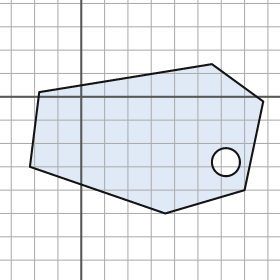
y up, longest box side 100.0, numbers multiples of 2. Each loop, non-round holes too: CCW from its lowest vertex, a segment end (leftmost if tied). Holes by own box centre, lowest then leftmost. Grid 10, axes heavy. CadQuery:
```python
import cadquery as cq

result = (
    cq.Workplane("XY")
    .moveTo(36.0, -50.0)
    .lineTo(70.0, -40.0)
    .lineTo(78.0, -2.0)
    .lineTo(56.0, 14.0)
    .lineTo(-18.0, 2.0)
    .lineTo(-22.0, -30.0)
    .close()
    .moveTo(62.0, -28.0)
    .circle(6.0)
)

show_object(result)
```